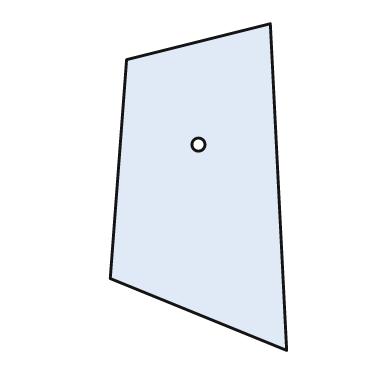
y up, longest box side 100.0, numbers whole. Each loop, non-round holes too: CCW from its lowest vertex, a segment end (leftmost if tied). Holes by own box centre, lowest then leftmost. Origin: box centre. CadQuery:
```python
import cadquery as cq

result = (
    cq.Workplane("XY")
    .moveTo(27.0, -50.0)
    .lineTo(22.0, 50.0)
    .lineTo(-22.0, 39.0)
    .lineTo(-27.0, -28.0)
    .close()
    .moveTo(0.0, 13.0)
    .circle(2.0)
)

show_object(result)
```